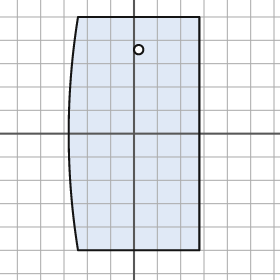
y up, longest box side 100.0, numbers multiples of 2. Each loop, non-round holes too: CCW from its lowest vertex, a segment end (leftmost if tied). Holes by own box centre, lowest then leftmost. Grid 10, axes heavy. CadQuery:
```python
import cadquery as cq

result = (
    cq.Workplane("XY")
    .moveTo(-24.0, -50.0)
    .lineTo(28.0, -50.0)
    .lineTo(28.0, 50.0)
    .lineTo(-24.0, 50.0)
    .threePointArc((-28.0, 0.0), (-24.0, -50.0))
    .close()
    .moveTo(2.0, 36.0)
    .circle(2.0)
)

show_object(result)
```